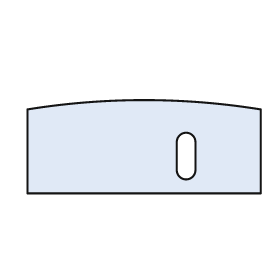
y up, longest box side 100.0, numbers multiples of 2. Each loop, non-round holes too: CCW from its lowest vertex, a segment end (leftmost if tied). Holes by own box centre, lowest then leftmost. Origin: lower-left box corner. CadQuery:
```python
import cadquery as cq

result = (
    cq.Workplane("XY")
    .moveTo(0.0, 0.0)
    .lineTo(100.0, 0.0)
    .lineTo(100.0, 36.0)
    .threePointArc((50.0, 40.0), (0.0, 36.0))
    .close()
    .moveTo(64.0, 10.0)
    .threePointArc((68.0, 6.0), (72.0, 10.0))
    .lineTo(72.0, 22.0)
    .threePointArc((68.0, 26.0), (64.0, 22.0))
    .close()
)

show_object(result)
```